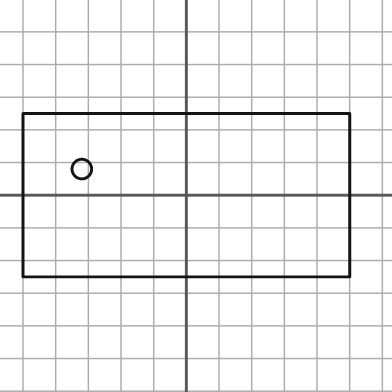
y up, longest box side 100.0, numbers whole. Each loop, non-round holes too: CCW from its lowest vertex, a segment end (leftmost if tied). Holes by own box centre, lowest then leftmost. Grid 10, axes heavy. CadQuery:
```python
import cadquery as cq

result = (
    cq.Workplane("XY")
    .moveTo(-50.0, -25.0)
    .lineTo(50.0, -25.0)
    .lineTo(50.0, 25.0)
    .lineTo(-50.0, 25.0)
    .close()
    .moveTo(-32.0, 8.0)
    .circle(3.0)
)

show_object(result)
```